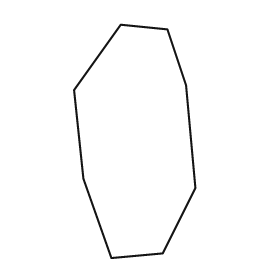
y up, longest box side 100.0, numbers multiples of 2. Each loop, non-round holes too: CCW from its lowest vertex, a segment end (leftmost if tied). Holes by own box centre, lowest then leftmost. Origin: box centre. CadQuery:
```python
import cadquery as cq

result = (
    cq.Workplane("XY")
    .moveTo(-10.0, -50.0)
    .lineTo(12.0, -48.0)
    .lineTo(26.0, -20.0)
    .lineTo(22.0, 24.0)
    .lineTo(14.0, 48.0)
    .lineTo(-6.0, 50.0)
    .lineTo(-26.0, 22.0)
    .lineTo(-22.0, -16.0)
    .close()
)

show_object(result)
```